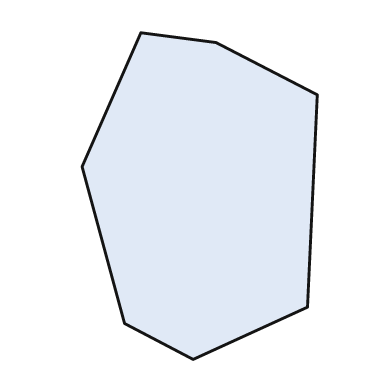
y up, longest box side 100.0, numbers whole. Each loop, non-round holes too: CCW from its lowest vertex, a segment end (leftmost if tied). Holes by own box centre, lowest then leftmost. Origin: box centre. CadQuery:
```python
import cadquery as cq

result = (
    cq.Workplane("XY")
    .moveTo(-2.0, -50.0)
    .lineTo(33.0, -34.0)
    .lineTo(36.0, 31.0)
    .lineTo(5.0, 47.0)
    .lineTo(-18.0, 50.0)
    .lineTo(-36.0, 9.0)
    .lineTo(-23.0, -39.0)
    .close()
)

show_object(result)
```